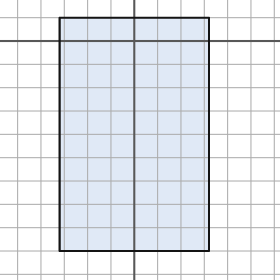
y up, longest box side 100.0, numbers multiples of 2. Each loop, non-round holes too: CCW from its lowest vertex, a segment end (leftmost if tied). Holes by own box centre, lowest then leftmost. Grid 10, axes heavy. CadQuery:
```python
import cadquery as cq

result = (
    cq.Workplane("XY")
    .moveTo(-32.0, -90.0)
    .lineTo(32.0, -90.0)
    .lineTo(32.0, 10.0)
    .lineTo(-32.0, 10.0)
    .close()
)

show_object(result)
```